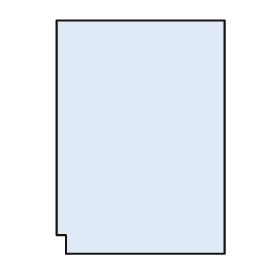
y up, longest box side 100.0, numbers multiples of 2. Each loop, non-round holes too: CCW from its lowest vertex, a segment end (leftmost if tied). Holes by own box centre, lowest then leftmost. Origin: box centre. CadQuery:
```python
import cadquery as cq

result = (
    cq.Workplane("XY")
    .moveTo(-32.0, -50.0)
    .lineTo(36.0, -50.0)
    .lineTo(36.0, 50.0)
    .lineTo(-36.0, 50.0)
    .lineTo(-36.0, -42.0)
    .lineTo(-32.0, -42.0)
    .close()
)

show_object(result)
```